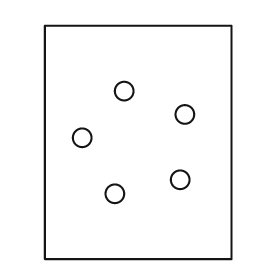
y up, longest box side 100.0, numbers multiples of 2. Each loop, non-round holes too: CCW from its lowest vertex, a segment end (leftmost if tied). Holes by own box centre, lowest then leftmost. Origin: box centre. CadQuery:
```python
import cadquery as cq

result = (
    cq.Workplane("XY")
    .moveTo(-40.0, -50.0)
    .lineTo(40.0, -50.0)
    .lineTo(40.0, 50.0)
    .lineTo(-40.0, 50.0)
    .close()
    .moveTo(-10.0, -22.0)
    .circle(4.0)
    .moveTo(18.0, -16.0)
    .circle(4.0)
    .moveTo(-24.0, 2.0)
    .circle(4.0)
    .moveTo(20.0, 12.0)
    .circle(4.0)
    .moveTo(-6.0, 22.0)
    .circle(4.0)
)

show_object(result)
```